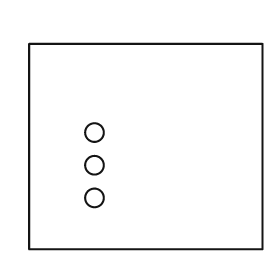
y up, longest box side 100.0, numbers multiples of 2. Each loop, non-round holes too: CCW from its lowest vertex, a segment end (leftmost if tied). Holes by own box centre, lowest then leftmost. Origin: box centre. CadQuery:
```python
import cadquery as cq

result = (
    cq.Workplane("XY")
    .moveTo(-50.0, -44.0)
    .lineTo(50.0, -44.0)
    .lineTo(50.0, 44.0)
    .lineTo(-50.0, 44.0)
    .close()
    .moveTo(-22.0, -22.0)
    .circle(4.0)
    .moveTo(-22.0, -8.0)
    .circle(4.0)
    .moveTo(-22.0, 6.0)
    .circle(4.0)
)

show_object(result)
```